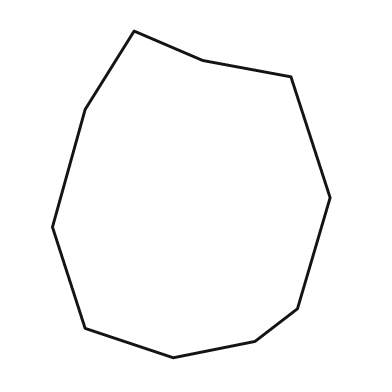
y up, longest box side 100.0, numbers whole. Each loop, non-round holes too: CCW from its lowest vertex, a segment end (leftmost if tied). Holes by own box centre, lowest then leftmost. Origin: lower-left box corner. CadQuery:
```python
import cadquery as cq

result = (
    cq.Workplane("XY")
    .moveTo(37.0, 0.0)
    .lineTo(62.0, 5.0)
    .lineTo(75.0, 15.0)
    .lineTo(85.0, 49.0)
    .lineTo(73.0, 86.0)
    .lineTo(46.0, 91.0)
    .lineTo(25.0, 100.0)
    .lineTo(10.0, 76.0)
    .lineTo(0.0, 40.0)
    .lineTo(10.0, 9.0)
    .close()
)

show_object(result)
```